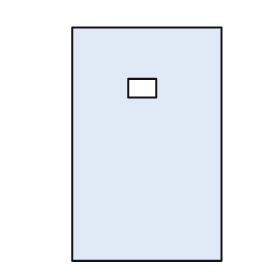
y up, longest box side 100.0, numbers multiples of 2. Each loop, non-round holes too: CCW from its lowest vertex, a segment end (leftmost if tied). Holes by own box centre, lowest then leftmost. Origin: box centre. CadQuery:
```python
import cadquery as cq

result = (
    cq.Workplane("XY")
    .moveTo(-32.0, -50.0)
    .lineTo(32.0, -50.0)
    .lineTo(32.0, 50.0)
    .lineTo(-32.0, 50.0)
    .close()
    .moveTo(-8.0, 20.0)
    .lineTo(4.0, 20.0)
    .lineTo(4.0, 28.0)
    .lineTo(-8.0, 28.0)
    .close()
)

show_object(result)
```